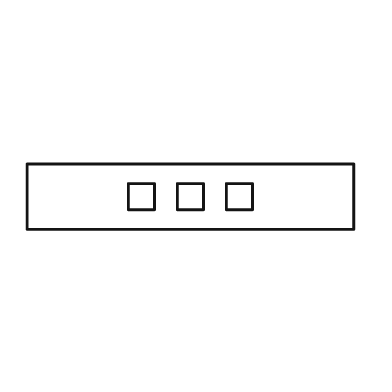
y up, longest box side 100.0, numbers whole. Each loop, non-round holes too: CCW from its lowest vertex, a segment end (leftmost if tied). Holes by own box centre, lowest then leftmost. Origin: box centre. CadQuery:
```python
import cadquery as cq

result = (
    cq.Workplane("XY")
    .moveTo(-50.0, -10.0)
    .lineTo(50.0, -10.0)
    .lineTo(50.0, 10.0)
    .lineTo(-50.0, 10.0)
    .close()
    .moveTo(-19.0, -4.0)
    .lineTo(-11.0, -4.0)
    .lineTo(-11.0, 4.0)
    .lineTo(-19.0, 4.0)
    .close()
    .moveTo(-4.0, -4.0)
    .lineTo(4.0, -4.0)
    .lineTo(4.0, 4.0)
    .lineTo(-4.0, 4.0)
    .close()
    .moveTo(11.0, -4.0)
    .lineTo(19.0, -4.0)
    .lineTo(19.0, 4.0)
    .lineTo(11.0, 4.0)
    .close()
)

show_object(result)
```